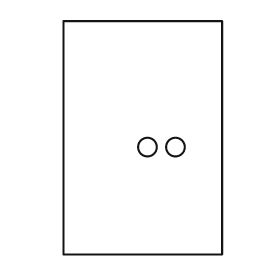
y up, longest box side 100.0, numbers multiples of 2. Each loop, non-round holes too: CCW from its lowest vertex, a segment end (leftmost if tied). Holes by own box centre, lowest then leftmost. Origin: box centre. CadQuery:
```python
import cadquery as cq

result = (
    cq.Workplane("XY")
    .moveTo(-34.0, -50.0)
    .lineTo(34.0, -50.0)
    .lineTo(34.0, 50.0)
    .lineTo(-34.0, 50.0)
    .close()
    .moveTo(2.0, -4.0)
    .circle(4.0)
    .moveTo(14.0, -4.0)
    .circle(4.0)
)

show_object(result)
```